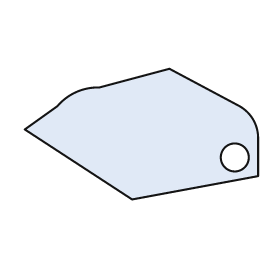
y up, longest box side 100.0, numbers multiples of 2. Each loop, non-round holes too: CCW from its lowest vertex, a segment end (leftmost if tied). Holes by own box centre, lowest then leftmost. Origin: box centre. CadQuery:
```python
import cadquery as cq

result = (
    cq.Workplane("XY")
    .moveTo(-4.0, -28.0)
    .lineTo(50.0, -18.0)
    .lineTo(50.0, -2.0)
    .threePointArc((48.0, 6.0), (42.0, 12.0))
    .lineTo(12.0, 28.0)
    .lineTo(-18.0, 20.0)
    .threePointArc((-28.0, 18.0), (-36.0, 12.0))
    .lineTo(-50.0, 2.0)
    .close()
    .moveTo(40.0, -10.0)
    .circle(6.0)
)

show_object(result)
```